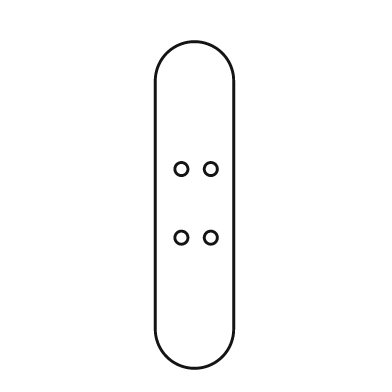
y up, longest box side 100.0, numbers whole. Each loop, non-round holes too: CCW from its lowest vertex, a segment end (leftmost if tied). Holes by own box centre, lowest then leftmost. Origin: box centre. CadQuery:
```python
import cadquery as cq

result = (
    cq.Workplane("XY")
    .moveTo(-12.0, -38.0)
    .threePointArc((0.0, -50.0), (12.0, -38.0))
    .lineTo(12.0, 38.0)
    .threePointArc((0.0, 50.0), (-12.0, 38.0))
    .close()
    .moveTo(-4.0, -10.0)
    .circle(2.0)
    .moveTo(5.0, -10.0)
    .circle(2.0)
    .moveTo(-4.0, 11.0)
    .circle(2.0)
    .moveTo(5.0, 11.0)
    .circle(2.0)
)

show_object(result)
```